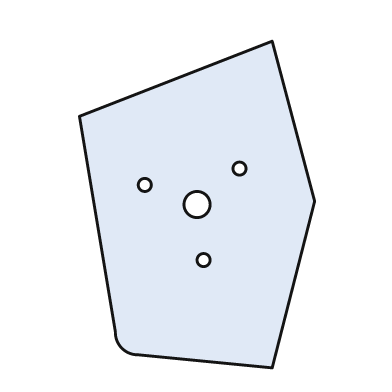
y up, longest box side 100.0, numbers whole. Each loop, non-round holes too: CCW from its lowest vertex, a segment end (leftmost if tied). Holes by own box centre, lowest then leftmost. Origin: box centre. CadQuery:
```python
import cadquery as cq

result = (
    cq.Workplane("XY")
    .moveTo(23.0, -50.0)
    .lineTo(36.0, 1.0)
    .lineTo(23.0, 50.0)
    .lineTo(-36.0, 27.0)
    .lineTo(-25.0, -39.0)
    .threePointArc((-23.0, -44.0), (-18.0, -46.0))
    .close()
    .moveTo(2.0, -17.0)
    .circle(2.0)
    .moveTo(0.0, 0.0)
    .circle(4.0)
    .moveTo(-16.0, 6.0)
    .circle(2.0)
    .moveTo(13.0, 11.0)
    .circle(2.0)
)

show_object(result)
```